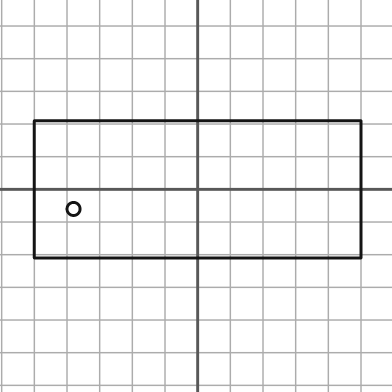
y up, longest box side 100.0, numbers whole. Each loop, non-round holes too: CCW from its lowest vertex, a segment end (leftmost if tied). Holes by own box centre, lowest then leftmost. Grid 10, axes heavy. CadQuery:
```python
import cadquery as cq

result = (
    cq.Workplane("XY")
    .moveTo(-50.0, -21.0)
    .lineTo(50.0, -21.0)
    .lineTo(50.0, 21.0)
    .lineTo(-50.0, 21.0)
    .close()
    .moveTo(-38.0, -6.0)
    .circle(2.0)
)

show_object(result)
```